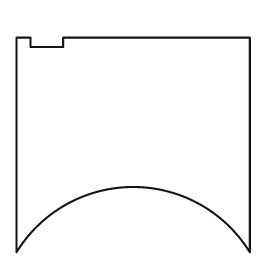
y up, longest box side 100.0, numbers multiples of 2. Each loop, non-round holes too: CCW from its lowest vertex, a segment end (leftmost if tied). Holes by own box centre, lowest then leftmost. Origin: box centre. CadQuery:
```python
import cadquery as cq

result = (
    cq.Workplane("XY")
    .moveTo(-50.0, -46.0)
    .threePointArc((0.0, -18.0), (50.0, -46.0))
    .lineTo(50.0, 46.0)
    .lineTo(-30.0, 46.0)
    .lineTo(-30.0, 42.0)
    .lineTo(-44.0, 42.0)
    .lineTo(-44.0, 46.0)
    .lineTo(-50.0, 46.0)
    .close()
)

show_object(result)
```